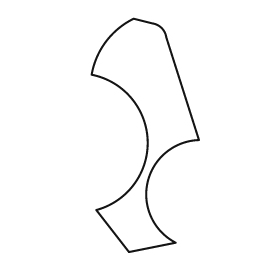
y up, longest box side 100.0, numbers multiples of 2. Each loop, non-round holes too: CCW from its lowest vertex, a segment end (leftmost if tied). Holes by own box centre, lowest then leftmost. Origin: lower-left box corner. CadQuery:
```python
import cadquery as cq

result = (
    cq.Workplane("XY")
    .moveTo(16.0, 0.0)
    .lineTo(36.0, 4.0)
    .threePointArc((24.0, 30.0), (46.0, 48.0))
    .lineTo(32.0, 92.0)
    .threePointArc((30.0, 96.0), (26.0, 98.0))
    .lineTo(18.0, 100.0)
    .threePointArc((6.0, 90.0), (0.0, 76.0))
    .threePointArc((24.0, 48.0), (2.0, 18.0))
    .close()
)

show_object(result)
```